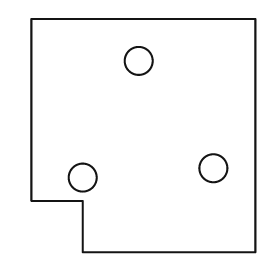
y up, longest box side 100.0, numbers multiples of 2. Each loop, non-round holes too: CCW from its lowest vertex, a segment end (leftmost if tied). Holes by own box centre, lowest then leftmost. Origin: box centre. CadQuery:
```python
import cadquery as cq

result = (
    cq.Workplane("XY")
    .moveTo(-26.0, -50.0)
    .lineTo(48.0, -50.0)
    .lineTo(48.0, 50.0)
    .lineTo(-48.0, 50.0)
    .lineTo(-48.0, -28.0)
    .lineTo(-26.0, -28.0)
    .close()
    .moveTo(-26.0, -18.0)
    .circle(6.0)
    .moveTo(30.0, -14.0)
    .circle(6.0)
    .moveTo(-2.0, 32.0)
    .circle(6.0)
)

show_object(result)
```